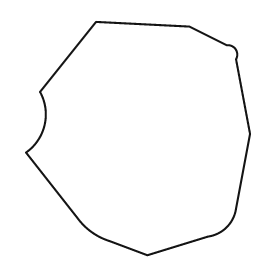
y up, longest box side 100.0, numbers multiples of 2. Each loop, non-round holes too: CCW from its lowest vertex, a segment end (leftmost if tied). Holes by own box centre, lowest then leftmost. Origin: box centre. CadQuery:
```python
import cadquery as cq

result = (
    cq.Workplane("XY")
    .moveTo(4.0, -50.0)
    .lineTo(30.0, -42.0)
    .threePointArc((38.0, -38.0), (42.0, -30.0))
    .lineTo(48.0, 2.0)
    .lineTo(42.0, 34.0)
    .threePointArc((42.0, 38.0), (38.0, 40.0))
    .lineTo(22.0, 48.0)
    .lineTo(-18.0, 50.0)
    .lineTo(-42.0, 20.0)
    .threePointArc((-40.0, 6.0), (-48.0, -6.0))
    .lineTo(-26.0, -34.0)
    .threePointArc((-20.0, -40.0), (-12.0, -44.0))
    .close()
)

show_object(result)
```